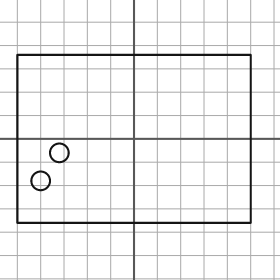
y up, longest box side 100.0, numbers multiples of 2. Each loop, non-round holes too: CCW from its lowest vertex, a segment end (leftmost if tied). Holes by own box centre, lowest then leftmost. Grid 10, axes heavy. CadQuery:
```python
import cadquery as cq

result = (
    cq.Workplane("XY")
    .moveTo(-50.0, -36.0)
    .lineTo(50.0, -36.0)
    .lineTo(50.0, 36.0)
    .lineTo(-50.0, 36.0)
    .close()
    .moveTo(-40.0, -18.0)
    .circle(4.0)
    .moveTo(-32.0, -6.0)
    .circle(4.0)
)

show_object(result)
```